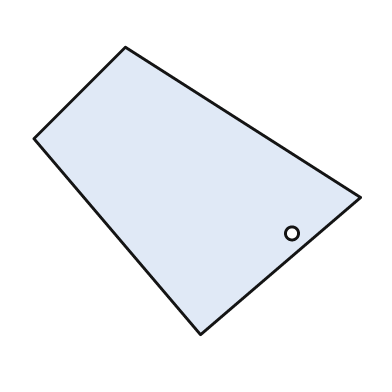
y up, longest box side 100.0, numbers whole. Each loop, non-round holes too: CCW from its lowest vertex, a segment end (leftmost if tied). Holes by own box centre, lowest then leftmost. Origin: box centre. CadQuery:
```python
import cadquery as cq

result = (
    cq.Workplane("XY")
    .moveTo(1.0, -44.0)
    .lineTo(50.0, -2.0)
    .lineTo(-22.0, 44.0)
    .lineTo(-50.0, 16.0)
    .close()
    .moveTo(29.0, -13.0)
    .circle(2.0)
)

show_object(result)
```